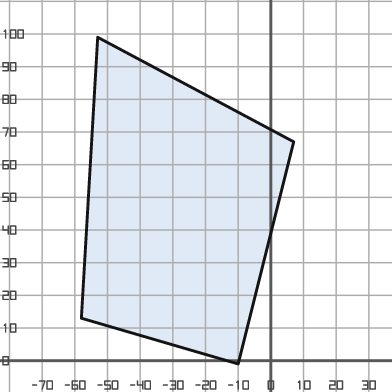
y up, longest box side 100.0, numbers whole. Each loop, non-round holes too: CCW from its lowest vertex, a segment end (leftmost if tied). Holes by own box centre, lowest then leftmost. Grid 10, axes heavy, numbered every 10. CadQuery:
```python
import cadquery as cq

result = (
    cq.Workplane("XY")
    .moveTo(-10.0, -1.0)
    .lineTo(7.0, 67.0)
    .lineTo(-53.0, 99.0)
    .lineTo(-58.0, 13.0)
    .close()
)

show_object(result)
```